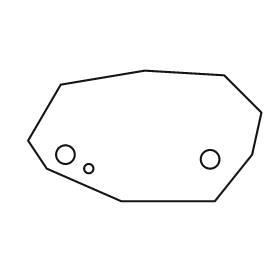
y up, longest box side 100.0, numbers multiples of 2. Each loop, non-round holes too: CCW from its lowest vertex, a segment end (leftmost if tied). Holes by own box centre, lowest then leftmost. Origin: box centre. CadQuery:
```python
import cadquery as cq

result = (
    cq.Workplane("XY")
    .moveTo(-10.0, -28.0)
    .lineTo(30.0, -28.0)
    .lineTo(46.0, -8.0)
    .lineTo(50.0, 10.0)
    .lineTo(34.0, 26.0)
    .lineTo(0.0, 28.0)
    .lineTo(-36.0, 22.0)
    .lineTo(-50.0, -2.0)
    .lineTo(-42.0, -14.0)
    .close()
    .moveTo(-24.0, -14.0)
    .circle(2.0)
    .moveTo(28.0, -10.0)
    .circle(4.0)
    .moveTo(-34.0, -8.0)
    .circle(4.0)
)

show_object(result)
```